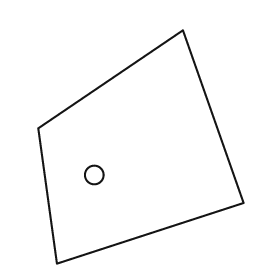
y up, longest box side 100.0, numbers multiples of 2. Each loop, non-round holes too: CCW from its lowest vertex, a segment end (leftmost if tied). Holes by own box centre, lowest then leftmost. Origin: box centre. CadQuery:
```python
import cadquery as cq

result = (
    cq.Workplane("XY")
    .moveTo(-36.0, -50.0)
    .lineTo(44.0, -24.0)
    .lineTo(18.0, 50.0)
    .lineTo(-44.0, 8.0)
    .close()
    .moveTo(-20.0, -12.0)
    .circle(4.0)
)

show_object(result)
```